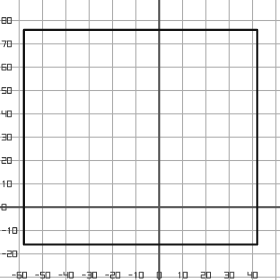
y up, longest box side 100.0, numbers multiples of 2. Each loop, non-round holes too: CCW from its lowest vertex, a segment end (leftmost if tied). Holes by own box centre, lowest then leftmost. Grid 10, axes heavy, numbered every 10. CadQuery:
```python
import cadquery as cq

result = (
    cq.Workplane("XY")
    .moveTo(-58.0, -16.0)
    .lineTo(42.0, -16.0)
    .lineTo(42.0, 76.0)
    .lineTo(-58.0, 76.0)
    .close()
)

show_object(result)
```